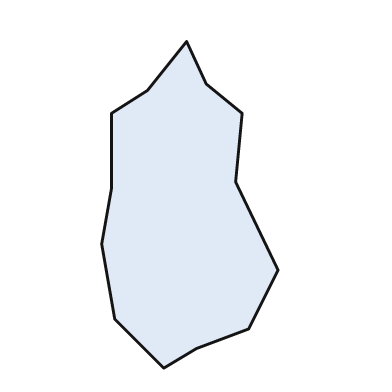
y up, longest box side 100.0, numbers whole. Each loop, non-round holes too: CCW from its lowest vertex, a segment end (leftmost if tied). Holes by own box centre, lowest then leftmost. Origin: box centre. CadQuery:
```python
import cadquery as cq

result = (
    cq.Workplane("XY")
    .moveTo(-8.0, -50.0)
    .lineTo(2.0, -44.0)
    .lineTo(18.0, -38.0)
    .lineTo(27.0, -20.0)
    .lineTo(14.0, 7.0)
    .lineTo(16.0, 28.0)
    .lineTo(5.0, 37.0)
    .lineTo(-1.0, 50.0)
    .lineTo(-13.0, 35.0)
    .lineTo(-24.0, 28.0)
    .lineTo(-24.0, 5.0)
    .lineTo(-27.0, -12.0)
    .lineTo(-23.0, -35.0)
    .close()
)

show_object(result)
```